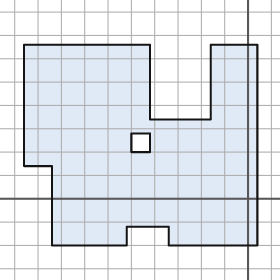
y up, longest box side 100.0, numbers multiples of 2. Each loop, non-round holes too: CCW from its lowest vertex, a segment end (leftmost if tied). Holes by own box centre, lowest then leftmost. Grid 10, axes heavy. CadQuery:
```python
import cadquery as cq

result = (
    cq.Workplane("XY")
    .moveTo(-84.0, -20.0)
    .lineTo(-52.0, -20.0)
    .lineTo(-52.0, -12.0)
    .lineTo(-34.0, -12.0)
    .lineTo(-34.0, -20.0)
    .lineTo(4.0, -20.0)
    .lineTo(4.0, 66.0)
    .lineTo(-16.0, 66.0)
    .lineTo(-16.0, 34.0)
    .lineTo(-42.0, 34.0)
    .lineTo(-42.0, 66.0)
    .lineTo(-96.0, 66.0)
    .lineTo(-96.0, 14.0)
    .lineTo(-84.0, 14.0)
    .close()
    .moveTo(-50.0, 20.0)
    .lineTo(-42.0, 20.0)
    .lineTo(-42.0, 28.0)
    .lineTo(-50.0, 28.0)
    .close()
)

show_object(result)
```